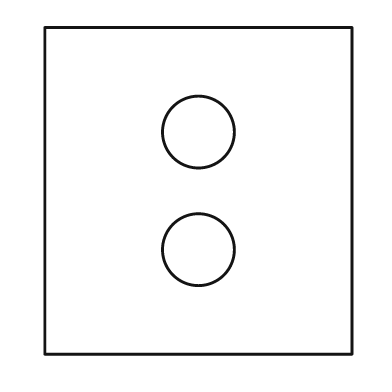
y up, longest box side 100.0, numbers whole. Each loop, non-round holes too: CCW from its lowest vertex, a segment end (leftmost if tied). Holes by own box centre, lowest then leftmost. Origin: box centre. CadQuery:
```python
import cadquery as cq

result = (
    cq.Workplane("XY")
    .moveTo(-47.0, -50.0)
    .lineTo(47.0, -50.0)
    .lineTo(47.0, 50.0)
    .lineTo(-47.0, 50.0)
    .close()
    .moveTo(0.0, -18.0)
    .circle(11.0)
    .moveTo(0.0, 18.0)
    .circle(11.0)
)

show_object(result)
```